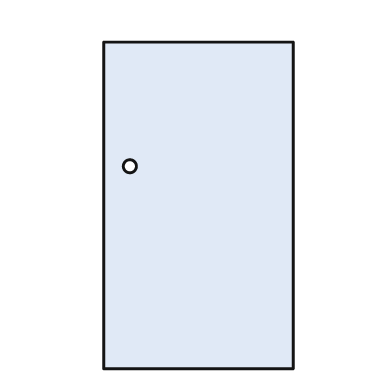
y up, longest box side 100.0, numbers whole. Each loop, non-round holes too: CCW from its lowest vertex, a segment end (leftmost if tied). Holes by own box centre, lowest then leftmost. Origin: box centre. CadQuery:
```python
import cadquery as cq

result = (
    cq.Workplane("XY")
    .moveTo(-29.0, -50.0)
    .lineTo(29.0, -50.0)
    .lineTo(29.0, 50.0)
    .lineTo(-29.0, 50.0)
    .close()
    .moveTo(-21.0, 12.0)
    .circle(2.0)
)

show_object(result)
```